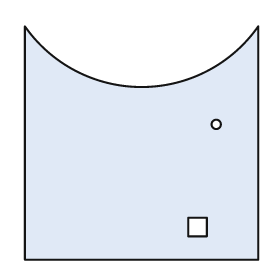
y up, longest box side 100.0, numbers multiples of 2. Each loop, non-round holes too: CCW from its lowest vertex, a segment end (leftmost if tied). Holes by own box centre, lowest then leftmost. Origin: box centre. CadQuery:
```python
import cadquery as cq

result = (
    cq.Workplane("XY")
    .moveTo(-50.0, -50.0)
    .lineTo(50.0, -50.0)
    .lineTo(50.0, 50.0)
    .threePointArc((0.0, 24.0), (-50.0, 50.0))
    .close()
    .moveTo(20.0, -40.0)
    .lineTo(28.0, -40.0)
    .lineTo(28.0, -32.0)
    .lineTo(20.0, -32.0)
    .close()
    .moveTo(32.0, 8.0)
    .circle(2.0)
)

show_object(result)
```